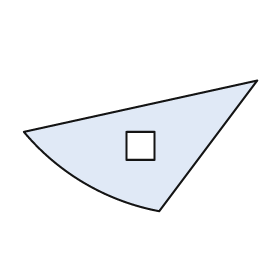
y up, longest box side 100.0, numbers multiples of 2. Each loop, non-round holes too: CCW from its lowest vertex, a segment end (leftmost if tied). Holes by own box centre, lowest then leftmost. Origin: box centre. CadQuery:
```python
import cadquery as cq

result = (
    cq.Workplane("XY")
    .moveTo(8.0, -28.0)
    .lineTo(50.0, 28.0)
    .lineTo(-50.0, 6.0)
    .threePointArc((-24.0, -16.0), (8.0, -28.0))
    .close()
    .moveTo(-6.0, -6.0)
    .lineTo(6.0, -6.0)
    .lineTo(6.0, 6.0)
    .lineTo(-6.0, 6.0)
    .close()
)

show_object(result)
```